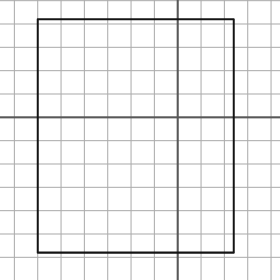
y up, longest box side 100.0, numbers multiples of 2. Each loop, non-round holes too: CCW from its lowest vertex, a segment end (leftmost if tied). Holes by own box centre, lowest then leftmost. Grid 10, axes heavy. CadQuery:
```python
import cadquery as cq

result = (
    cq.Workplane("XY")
    .moveTo(-60.0, -58.0)
    .lineTo(24.0, -58.0)
    .lineTo(24.0, 42.0)
    .lineTo(-60.0, 42.0)
    .close()
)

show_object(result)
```